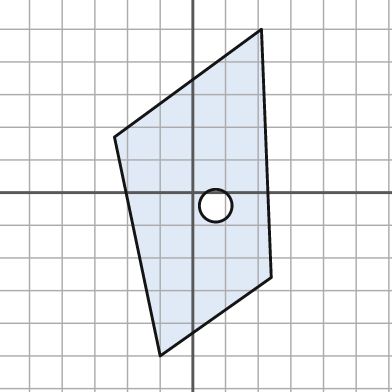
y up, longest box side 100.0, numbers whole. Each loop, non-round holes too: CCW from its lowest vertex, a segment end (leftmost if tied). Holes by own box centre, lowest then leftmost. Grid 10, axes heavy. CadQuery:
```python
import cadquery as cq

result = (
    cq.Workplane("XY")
    .moveTo(-10.0, -50.0)
    .lineTo(24.0, -26.0)
    .lineTo(21.0, 50.0)
    .lineTo(-24.0, 17.0)
    .close()
    .moveTo(7.0, -4.0)
    .circle(5.0)
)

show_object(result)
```